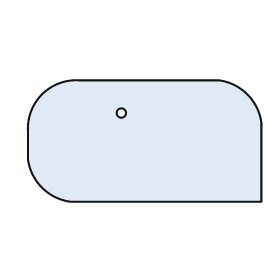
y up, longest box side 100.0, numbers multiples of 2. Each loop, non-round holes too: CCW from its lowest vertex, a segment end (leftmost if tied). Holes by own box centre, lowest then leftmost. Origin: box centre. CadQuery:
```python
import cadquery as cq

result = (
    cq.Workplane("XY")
    .moveTo(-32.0, -26.0)
    .lineTo(50.0, -26.0)
    .lineTo(50.0, 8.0)
    .threePointArc((44.0, 20.0), (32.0, 26.0))
    .lineTo(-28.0, 26.0)
    .threePointArc((-44.0, 20.0), (-50.0, 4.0))
    .lineTo(-50.0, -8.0)
    .threePointArc((-44.0, -20.0), (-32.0, -26.0))
    .close()
    .moveTo(-10.0, 12.0)
    .circle(2.0)
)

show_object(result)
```